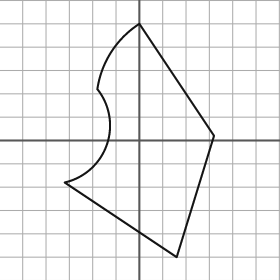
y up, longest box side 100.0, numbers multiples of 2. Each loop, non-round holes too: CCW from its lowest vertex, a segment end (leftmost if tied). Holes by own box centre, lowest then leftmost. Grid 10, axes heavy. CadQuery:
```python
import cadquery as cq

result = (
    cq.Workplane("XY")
    .moveTo(16.0, -50.0)
    .lineTo(32.0, 2.0)
    .lineTo(0.0, 50.0)
    .threePointArc((-12.0, 38.0), (-18.0, 22.0))
    .threePointArc((-14.0, -2.0), (-32.0, -18.0))
    .close()
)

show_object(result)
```